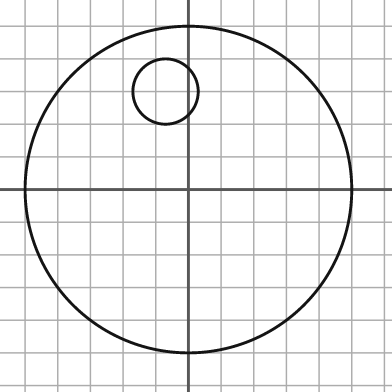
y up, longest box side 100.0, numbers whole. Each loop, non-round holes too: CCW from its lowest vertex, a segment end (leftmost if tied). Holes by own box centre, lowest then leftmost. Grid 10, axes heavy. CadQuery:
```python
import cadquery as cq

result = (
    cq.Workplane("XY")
    .moveTo(0.0, 0.0)
    .circle(50.0)
    .moveTo(-7.0, 30.0)
    .circle(10.0)
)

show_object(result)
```